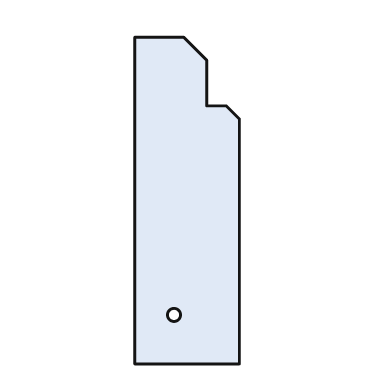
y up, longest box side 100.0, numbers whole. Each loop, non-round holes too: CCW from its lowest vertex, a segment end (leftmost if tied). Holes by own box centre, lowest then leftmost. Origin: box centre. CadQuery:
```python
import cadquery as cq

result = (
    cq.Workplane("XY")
    .moveTo(-16.0, -50.0)
    .lineTo(16.0, -50.0)
    .lineTo(16.0, 25.0)
    .lineTo(12.0, 29.0)
    .lineTo(6.0, 29.0)
    .lineTo(6.0, 43.0)
    .lineTo(-1.0, 50.0)
    .lineTo(-16.0, 50.0)
    .close()
    .moveTo(-4.0, -35.0)
    .circle(2.0)
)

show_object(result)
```